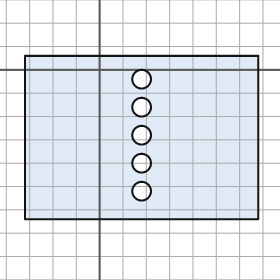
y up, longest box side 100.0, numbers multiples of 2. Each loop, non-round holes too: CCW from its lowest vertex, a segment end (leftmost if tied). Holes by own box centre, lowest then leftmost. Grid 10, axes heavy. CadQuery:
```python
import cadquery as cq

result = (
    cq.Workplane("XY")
    .moveTo(-32.0, -64.0)
    .lineTo(68.0, -64.0)
    .lineTo(68.0, 6.0)
    .lineTo(-32.0, 6.0)
    .close()
    .moveTo(18.0, -52.0)
    .circle(4.0)
    .moveTo(18.0, -40.0)
    .circle(4.0)
    .moveTo(18.0, -28.0)
    .circle(4.0)
    .moveTo(18.0, -16.0)
    .circle(4.0)
    .moveTo(18.0, -4.0)
    .circle(4.0)
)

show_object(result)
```